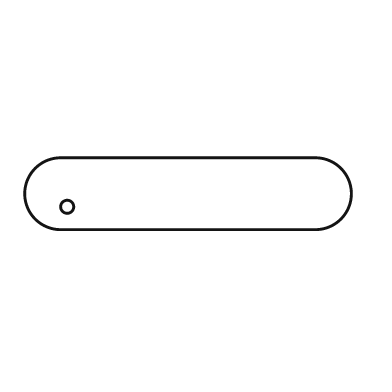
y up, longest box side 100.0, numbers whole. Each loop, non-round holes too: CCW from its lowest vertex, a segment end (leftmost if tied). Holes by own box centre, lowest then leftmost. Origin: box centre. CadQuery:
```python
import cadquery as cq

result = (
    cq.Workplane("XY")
    .moveTo(-39.0, -11.0)
    .lineTo(39.0, -11.0)
    .threePointArc((50.0, 0.0), (39.0, 11.0))
    .lineTo(-39.0, 11.0)
    .threePointArc((-50.0, 0.0), (-39.0, -11.0))
    .close()
    .moveTo(-37.0, -4.0)
    .circle(2.0)
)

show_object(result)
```